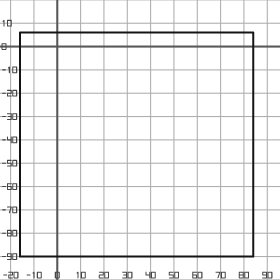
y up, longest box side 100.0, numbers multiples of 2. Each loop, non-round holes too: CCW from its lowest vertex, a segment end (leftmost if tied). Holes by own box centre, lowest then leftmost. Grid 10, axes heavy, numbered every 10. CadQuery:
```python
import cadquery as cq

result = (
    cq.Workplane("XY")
    .moveTo(-16.0, -90.0)
    .lineTo(84.0, -90.0)
    .lineTo(84.0, 6.0)
    .lineTo(-16.0, 6.0)
    .close()
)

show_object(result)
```